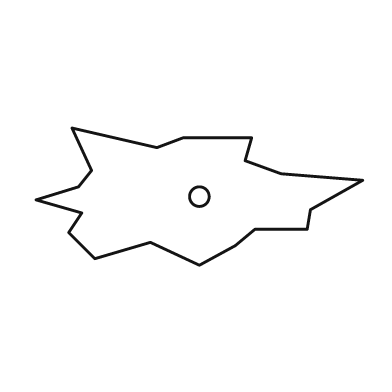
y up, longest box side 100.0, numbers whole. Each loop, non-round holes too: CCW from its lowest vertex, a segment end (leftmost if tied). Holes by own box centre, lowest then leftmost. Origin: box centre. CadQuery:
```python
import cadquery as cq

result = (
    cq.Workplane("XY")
    .moveTo(0.0, -21.0)
    .lineTo(11.0, -15.0)
    .lineTo(17.0, -10.0)
    .lineTo(33.0, -10.0)
    .lineTo(34.0, -4.0)
    .lineTo(50.0, 5.0)
    .lineTo(25.0, 7.0)
    .lineTo(14.0, 11.0)
    .lineTo(16.0, 18.0)
    .lineTo(-5.0, 18.0)
    .lineTo(-13.0, 15.0)
    .lineTo(-39.0, 21.0)
    .lineTo(-33.0, 8.0)
    .lineTo(-37.0, 3.0)
    .lineTo(-50.0, -1.0)
    .lineTo(-36.0, -5.0)
    .lineTo(-40.0, -11.0)
    .lineTo(-32.0, -19.0)
    .lineTo(-15.0, -14.0)
    .close()
    .moveTo(0.0, 0.0)
    .circle(3.0)
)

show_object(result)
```